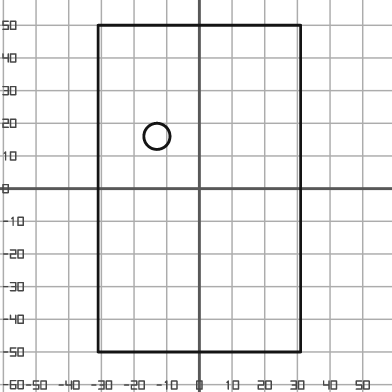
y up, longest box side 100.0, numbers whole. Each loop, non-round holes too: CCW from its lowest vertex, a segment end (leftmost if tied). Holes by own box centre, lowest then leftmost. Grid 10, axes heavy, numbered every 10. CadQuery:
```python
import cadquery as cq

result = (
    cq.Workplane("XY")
    .moveTo(-31.0, -50.0)
    .lineTo(31.0, -50.0)
    .lineTo(31.0, 50.0)
    .lineTo(-31.0, 50.0)
    .close()
    .moveTo(-13.0, 16.0)
    .circle(4.0)
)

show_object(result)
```